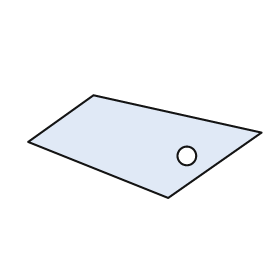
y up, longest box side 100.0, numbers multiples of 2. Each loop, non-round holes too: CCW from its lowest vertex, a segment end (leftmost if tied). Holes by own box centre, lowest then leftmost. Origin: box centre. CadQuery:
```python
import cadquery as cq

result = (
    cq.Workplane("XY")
    .moveTo(10.0, -22.0)
    .lineTo(50.0, 6.0)
    .lineTo(-22.0, 22.0)
    .lineTo(-50.0, 2.0)
    .close()
    .moveTo(18.0, -4.0)
    .circle(4.0)
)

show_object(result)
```